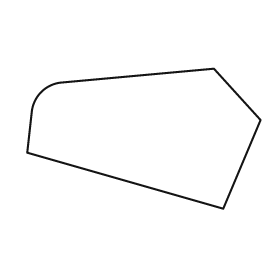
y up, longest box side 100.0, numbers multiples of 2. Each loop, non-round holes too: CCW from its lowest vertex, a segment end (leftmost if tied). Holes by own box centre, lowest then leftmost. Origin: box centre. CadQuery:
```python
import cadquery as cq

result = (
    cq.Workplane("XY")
    .moveTo(34.0, -30.0)
    .lineTo(50.0, 8.0)
    .lineTo(30.0, 30.0)
    .lineTo(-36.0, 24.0)
    .threePointArc((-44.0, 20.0), (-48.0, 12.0))
    .lineTo(-50.0, -6.0)
    .close()
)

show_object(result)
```